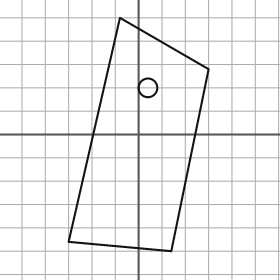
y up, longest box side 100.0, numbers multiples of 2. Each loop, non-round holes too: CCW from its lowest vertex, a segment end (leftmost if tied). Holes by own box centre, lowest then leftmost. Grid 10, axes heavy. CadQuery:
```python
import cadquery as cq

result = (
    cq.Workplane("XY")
    .moveTo(14.0, -50.0)
    .lineTo(30.0, 28.0)
    .lineTo(-8.0, 50.0)
    .lineTo(-30.0, -46.0)
    .close()
    .moveTo(4.0, 20.0)
    .circle(4.0)
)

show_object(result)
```